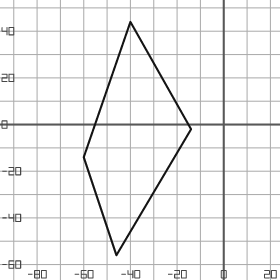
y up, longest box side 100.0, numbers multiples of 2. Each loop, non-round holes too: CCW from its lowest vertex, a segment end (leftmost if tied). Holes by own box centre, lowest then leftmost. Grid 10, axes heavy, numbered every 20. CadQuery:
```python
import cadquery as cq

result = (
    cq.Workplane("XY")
    .moveTo(-46.0, -56.0)
    .lineTo(-14.0, -2.0)
    .lineTo(-40.0, 44.0)
    .lineTo(-60.0, -14.0)
    .close()
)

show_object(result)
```